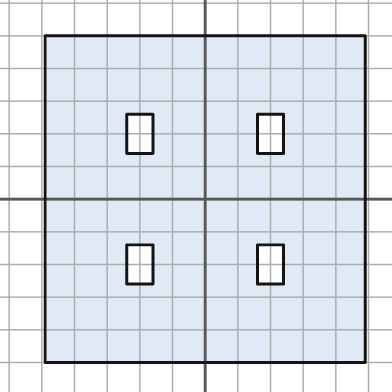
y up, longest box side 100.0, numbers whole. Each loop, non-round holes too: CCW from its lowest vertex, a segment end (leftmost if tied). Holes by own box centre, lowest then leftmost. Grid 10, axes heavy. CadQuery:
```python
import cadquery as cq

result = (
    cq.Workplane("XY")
    .moveTo(-49.0, -50.0)
    .lineTo(49.0, -50.0)
    .lineTo(49.0, 50.0)
    .lineTo(-49.0, 50.0)
    .close()
    .moveTo(-24.0, -26.0)
    .lineTo(-16.0, -26.0)
    .lineTo(-16.0, -14.0)
    .lineTo(-24.0, -14.0)
    .close()
    .moveTo(16.0, -26.0)
    .lineTo(24.0, -26.0)
    .lineTo(24.0, -14.0)
    .lineTo(16.0, -14.0)
    .close()
    .moveTo(-24.0, 14.0)
    .lineTo(-16.0, 14.0)
    .lineTo(-16.0, 26.0)
    .lineTo(-24.0, 26.0)
    .close()
    .moveTo(16.0, 14.0)
    .lineTo(24.0, 14.0)
    .lineTo(24.0, 26.0)
    .lineTo(16.0, 26.0)
    .close()
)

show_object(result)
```